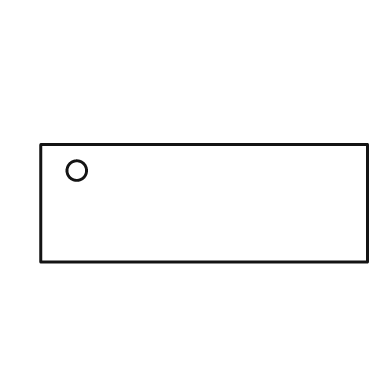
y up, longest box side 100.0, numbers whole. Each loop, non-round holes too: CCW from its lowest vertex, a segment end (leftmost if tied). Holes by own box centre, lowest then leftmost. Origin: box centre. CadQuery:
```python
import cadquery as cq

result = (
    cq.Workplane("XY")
    .moveTo(-50.0, -18.0)
    .lineTo(50.0, -18.0)
    .lineTo(50.0, 18.0)
    .lineTo(-50.0, 18.0)
    .close()
    .moveTo(-39.0, 10.0)
    .circle(3.0)
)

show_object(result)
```